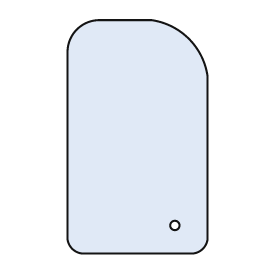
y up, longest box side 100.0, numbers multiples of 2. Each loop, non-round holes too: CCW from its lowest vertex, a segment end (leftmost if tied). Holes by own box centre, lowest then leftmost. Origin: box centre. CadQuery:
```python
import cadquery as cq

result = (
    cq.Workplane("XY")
    .moveTo(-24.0, -50.0)
    .lineTo(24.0, -50.0)
    .threePointArc((28.0, -48.0), (30.0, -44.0))
    .lineTo(30.0, 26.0)
    .threePointArc((22.0, 42.0), (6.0, 50.0))
    .lineTo(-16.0, 50.0)
    .threePointArc((-26.0, 46.0), (-30.0, 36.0))
    .lineTo(-30.0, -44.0)
    .threePointArc((-28.0, -48.0), (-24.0, -50.0))
    .close()
    .moveTo(16.0, -38.0)
    .circle(2.0)
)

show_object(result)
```